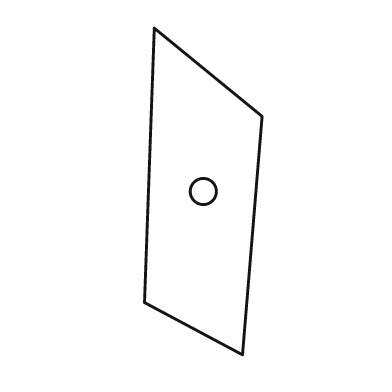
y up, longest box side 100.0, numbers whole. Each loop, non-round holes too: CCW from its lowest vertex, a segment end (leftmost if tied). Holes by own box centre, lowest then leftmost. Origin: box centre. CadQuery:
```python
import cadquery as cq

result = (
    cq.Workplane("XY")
    .moveTo(12.0, -50.0)
    .lineTo(18.0, 23.0)
    .lineTo(-15.0, 50.0)
    .lineTo(-18.0, -34.0)
    .close()
    .moveTo(0.0, 0.0)
    .circle(4.0)
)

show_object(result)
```